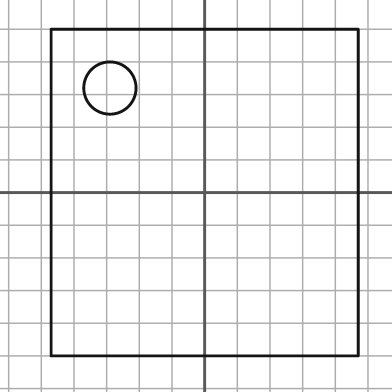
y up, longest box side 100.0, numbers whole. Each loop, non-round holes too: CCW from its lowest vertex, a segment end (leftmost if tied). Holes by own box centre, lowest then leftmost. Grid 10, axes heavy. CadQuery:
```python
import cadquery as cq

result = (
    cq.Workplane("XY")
    .moveTo(-47.0, -50.0)
    .lineTo(47.0, -50.0)
    .lineTo(47.0, 50.0)
    .lineTo(-47.0, 50.0)
    .close()
    .moveTo(-29.0, 32.0)
    .circle(8.0)
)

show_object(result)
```